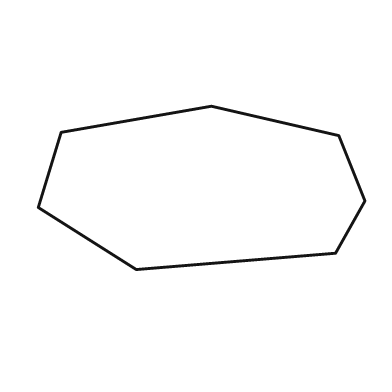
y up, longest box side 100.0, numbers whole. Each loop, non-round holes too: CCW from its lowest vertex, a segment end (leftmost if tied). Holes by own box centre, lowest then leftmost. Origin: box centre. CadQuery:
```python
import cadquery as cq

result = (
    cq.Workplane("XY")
    .moveTo(-20.0, -25.0)
    .lineTo(41.0, -20.0)
    .lineTo(50.0, -4.0)
    .lineTo(42.0, 16.0)
    .lineTo(3.0, 25.0)
    .lineTo(-43.0, 17.0)
    .lineTo(-50.0, -6.0)
    .close()
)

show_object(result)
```